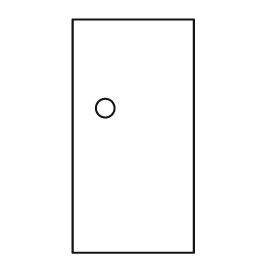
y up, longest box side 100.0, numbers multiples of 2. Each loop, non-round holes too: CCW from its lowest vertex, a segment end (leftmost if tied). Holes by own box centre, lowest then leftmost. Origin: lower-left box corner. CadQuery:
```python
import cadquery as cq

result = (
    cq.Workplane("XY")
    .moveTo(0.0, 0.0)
    .lineTo(52.0, 0.0)
    .lineTo(52.0, 100.0)
    .lineTo(0.0, 100.0)
    .close()
    .moveTo(14.0, 62.0)
    .circle(4.0)
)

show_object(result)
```